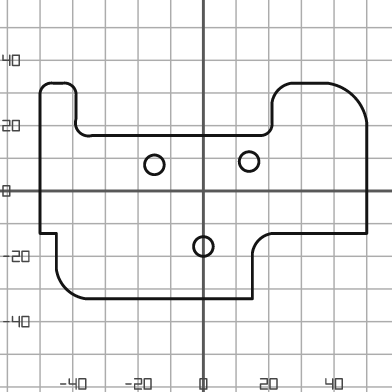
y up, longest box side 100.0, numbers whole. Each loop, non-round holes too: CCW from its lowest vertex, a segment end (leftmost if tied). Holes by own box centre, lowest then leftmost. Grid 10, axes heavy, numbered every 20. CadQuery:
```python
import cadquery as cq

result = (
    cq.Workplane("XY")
    .moveTo(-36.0, -33.0)
    .lineTo(15.0, -33.0)
    .lineTo(15.0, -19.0)
    .threePointArc((17.0, -15.0), (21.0, -13.0))
    .lineTo(50.0, -13.0)
    .lineTo(50.0, 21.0)
    .threePointArc((46.0, 29.0), (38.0, 33.0))
    .lineTo(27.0, 33.0)
    .threePointArc((23.0, 31.0), (21.0, 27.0))
    .lineTo(21.0, 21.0)
    .threePointArc((20.0, 18.0), (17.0, 17.0))
    .lineTo(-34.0, 17.0)
    .threePointArc((-38.0, 18.0), (-39.0, 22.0))
    .lineTo(-39.0, 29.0)
    .threePointArc((-40.0, 32.0), (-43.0, 33.0))
    .lineTo(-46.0, 33.0)
    .threePointArc((-49.0, 32.0), (-50.0, 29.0))
    .lineTo(-50.0, -13.0)
    .lineTo(-45.0, -13.0)
    .lineTo(-45.0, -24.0)
    .threePointArc((-42.0, -30.0), (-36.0, -33.0))
    .close()
    .moveTo(0.0, -17.0)
    .circle(3.0)
    .moveTo(-15.0, 8.0)
    .circle(3.0)
    .moveTo(14.0, 9.0)
    .circle(3.0)
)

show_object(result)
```